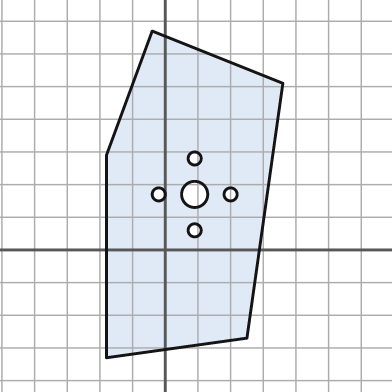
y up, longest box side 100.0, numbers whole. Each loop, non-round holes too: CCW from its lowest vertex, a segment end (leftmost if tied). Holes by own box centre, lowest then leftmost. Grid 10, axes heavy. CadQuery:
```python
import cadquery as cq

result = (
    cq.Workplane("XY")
    .moveTo(-18.0, -33.0)
    .lineTo(25.0, -27.0)
    .lineTo(36.0, 51.0)
    .lineTo(-4.0, 67.0)
    .lineTo(-18.0, 29.0)
    .close()
    .moveTo(9.0, 6.0)
    .circle(2.0)
    .moveTo(-2.0, 17.0)
    .circle(2.0)
    .moveTo(9.0, 17.0)
    .circle(4.0)
    .moveTo(20.0, 17.0)
    .circle(2.0)
    .moveTo(9.0, 28.0)
    .circle(2.0)
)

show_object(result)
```